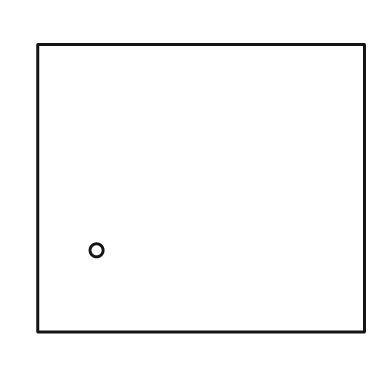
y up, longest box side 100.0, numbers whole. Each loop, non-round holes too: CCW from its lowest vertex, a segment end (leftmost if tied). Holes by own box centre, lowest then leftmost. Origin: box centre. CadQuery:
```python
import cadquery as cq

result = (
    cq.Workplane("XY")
    .moveTo(-50.0, -44.0)
    .lineTo(50.0, -44.0)
    .lineTo(50.0, 44.0)
    .lineTo(-50.0, 44.0)
    .close()
    .moveTo(-32.0, -19.0)
    .circle(2.0)
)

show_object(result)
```